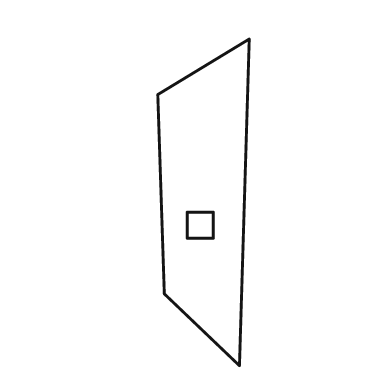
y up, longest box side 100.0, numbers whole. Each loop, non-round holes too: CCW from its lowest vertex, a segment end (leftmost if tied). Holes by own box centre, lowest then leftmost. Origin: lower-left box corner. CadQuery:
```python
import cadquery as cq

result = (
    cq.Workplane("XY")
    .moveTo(25.0, 0.0)
    .lineTo(28.0, 100.0)
    .lineTo(0.0, 83.0)
    .lineTo(2.0, 22.0)
    .close()
    .moveTo(9.0, 39.0)
    .lineTo(17.0, 39.0)
    .lineTo(17.0, 47.0)
    .lineTo(9.0, 47.0)
    .close()
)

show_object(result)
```